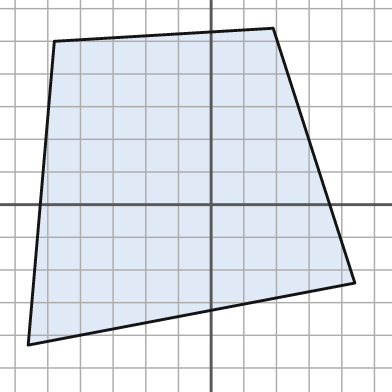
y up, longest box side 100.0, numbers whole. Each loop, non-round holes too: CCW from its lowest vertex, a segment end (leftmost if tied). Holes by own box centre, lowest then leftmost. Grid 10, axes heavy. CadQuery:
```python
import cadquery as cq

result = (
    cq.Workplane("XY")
    .moveTo(-56.0, -43.0)
    .lineTo(44.0, -24.0)
    .lineTo(19.0, 54.0)
    .lineTo(-48.0, 50.0)
    .close()
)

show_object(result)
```